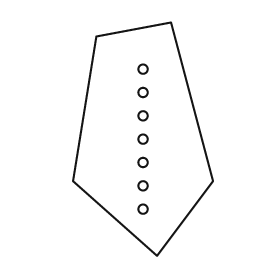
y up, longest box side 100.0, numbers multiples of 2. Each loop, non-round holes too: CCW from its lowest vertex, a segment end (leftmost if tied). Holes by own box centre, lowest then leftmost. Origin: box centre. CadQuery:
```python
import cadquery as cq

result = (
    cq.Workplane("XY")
    .moveTo(6.0, -50.0)
    .lineTo(30.0, -18.0)
    .lineTo(12.0, 50.0)
    .lineTo(-20.0, 44.0)
    .lineTo(-30.0, -18.0)
    .close()
    .moveTo(0.0, -30.0)
    .circle(2.0)
    .moveTo(0.0, -20.0)
    .circle(2.0)
    .moveTo(0.0, -10.0)
    .circle(2.0)
    .moveTo(0.0, 0.0)
    .circle(2.0)
    .moveTo(0.0, 10.0)
    .circle(2.0)
    .moveTo(0.0, 20.0)
    .circle(2.0)
    .moveTo(0.0, 30.0)
    .circle(2.0)
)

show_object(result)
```